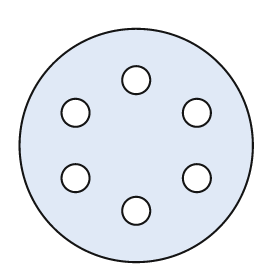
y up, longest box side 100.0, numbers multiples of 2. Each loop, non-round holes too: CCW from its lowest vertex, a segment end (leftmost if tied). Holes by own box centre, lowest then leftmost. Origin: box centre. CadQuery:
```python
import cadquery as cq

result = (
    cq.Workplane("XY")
    .moveTo(0.0, 0.0)
    .circle(50.0)
    .moveTo(0.0, -28.0)
    .circle(6.0)
    .moveTo(-26.0, -14.0)
    .circle(6.0)
    .moveTo(26.0, -14.0)
    .circle(6.0)
    .moveTo(-26.0, 14.0)
    .circle(6.0)
    .moveTo(26.0, 14.0)
    .circle(6.0)
    .moveTo(0.0, 28.0)
    .circle(6.0)
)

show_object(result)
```